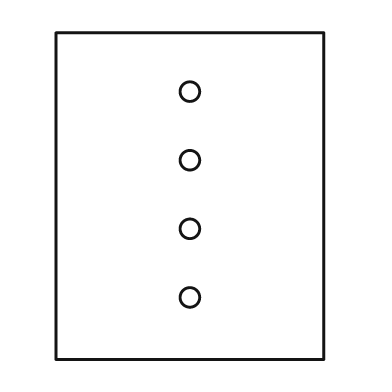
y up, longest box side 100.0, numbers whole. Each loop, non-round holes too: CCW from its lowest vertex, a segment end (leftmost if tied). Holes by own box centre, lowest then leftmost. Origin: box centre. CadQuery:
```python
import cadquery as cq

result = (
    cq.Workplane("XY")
    .moveTo(-41.0, -50.0)
    .lineTo(41.0, -50.0)
    .lineTo(41.0, 50.0)
    .lineTo(-41.0, 50.0)
    .close()
    .moveTo(0.0, -31.0)
    .circle(3.0)
    .moveTo(0.0, -10.0)
    .circle(3.0)
    .moveTo(0.0, 11.0)
    .circle(3.0)
    .moveTo(0.0, 32.0)
    .circle(3.0)
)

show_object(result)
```